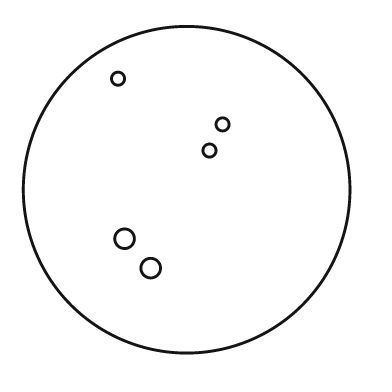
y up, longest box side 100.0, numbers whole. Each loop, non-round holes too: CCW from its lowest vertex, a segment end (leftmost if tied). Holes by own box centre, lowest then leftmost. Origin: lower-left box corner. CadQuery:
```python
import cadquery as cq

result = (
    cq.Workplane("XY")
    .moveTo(50.0, 50.0)
    .circle(50.0)
    .moveTo(39.0, 26.0)
    .circle(3.0)
    .moveTo(31.0, 35.0)
    .circle(3.0)
    .moveTo(57.0, 62.0)
    .circle(2.0)
    .moveTo(61.0, 70.0)
    .circle(2.0)
    .moveTo(29.0, 84.0)
    .circle(2.0)
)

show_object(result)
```